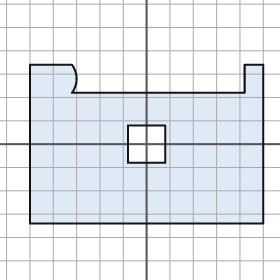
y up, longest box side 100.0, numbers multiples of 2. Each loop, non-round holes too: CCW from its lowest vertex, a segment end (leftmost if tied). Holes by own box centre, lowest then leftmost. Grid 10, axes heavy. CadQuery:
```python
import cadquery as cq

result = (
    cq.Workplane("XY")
    .moveTo(-50.0, -34.0)
    .lineTo(50.0, -34.0)
    .lineTo(50.0, 34.0)
    .lineTo(42.0, 34.0)
    .lineTo(42.0, 22.0)
    .lineTo(-32.0, 22.0)
    .threePointArc((-30.0, 28.0), (-32.0, 34.0))
    .lineTo(-50.0, 34.0)
    .close()
    .moveTo(-8.0, -8.0)
    .lineTo(8.0, -8.0)
    .lineTo(8.0, 8.0)
    .lineTo(-8.0, 8.0)
    .close()
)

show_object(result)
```